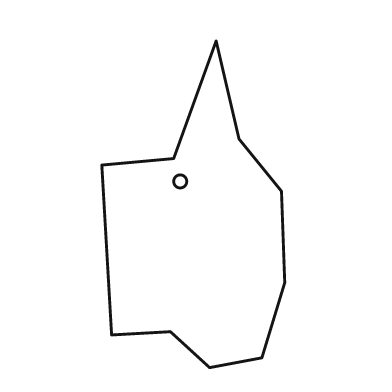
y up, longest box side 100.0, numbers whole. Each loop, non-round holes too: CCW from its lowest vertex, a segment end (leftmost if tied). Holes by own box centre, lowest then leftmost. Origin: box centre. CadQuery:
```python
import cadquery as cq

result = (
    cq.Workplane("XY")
    .moveTo(5.0, -50.0)
    .lineTo(21.0, -47.0)
    .lineTo(28.0, -24.0)
    .lineTo(27.0, 4.0)
    .lineTo(14.0, 20.0)
    .lineTo(7.0, 50.0)
    .lineTo(-6.0, 14.0)
    .lineTo(-28.0, 12.0)
    .lineTo(-25.0, -40.0)
    .lineTo(-7.0, -39.0)
    .close()
    .moveTo(-4.0, 7.0)
    .circle(2.0)
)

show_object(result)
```